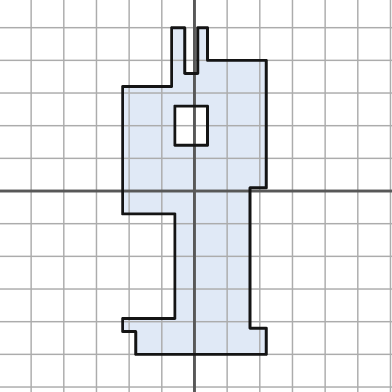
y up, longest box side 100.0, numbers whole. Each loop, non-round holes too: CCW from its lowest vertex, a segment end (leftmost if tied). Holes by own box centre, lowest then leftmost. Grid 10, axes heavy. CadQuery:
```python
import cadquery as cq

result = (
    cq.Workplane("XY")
    .moveTo(-18.0, -50.0)
    .lineTo(22.0, -50.0)
    .lineTo(22.0, -42.0)
    .lineTo(17.0, -42.0)
    .lineTo(17.0, 1.0)
    .lineTo(22.0, 1.0)
    .lineTo(22.0, 40.0)
    .lineTo(4.0, 40.0)
    .lineTo(4.0, 50.0)
    .lineTo(1.0, 50.0)
    .lineTo(1.0, 36.0)
    .lineTo(-3.0, 36.0)
    .lineTo(-3.0, 50.0)
    .lineTo(-7.0, 50.0)
    .lineTo(-7.0, 32.0)
    .lineTo(-22.0, 32.0)
    .lineTo(-22.0, -7.0)
    .lineTo(-6.0, -7.0)
    .lineTo(-6.0, -39.0)
    .lineTo(-22.0, -39.0)
    .lineTo(-22.0, -43.0)
    .lineTo(-18.0, -43.0)
    .close()
    .moveTo(-6.0, 14.0)
    .lineTo(4.0, 14.0)
    .lineTo(4.0, 26.0)
    .lineTo(-6.0, 26.0)
    .close()
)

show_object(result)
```